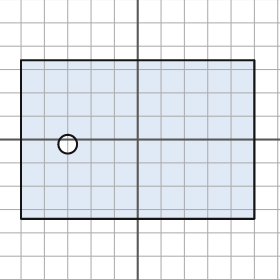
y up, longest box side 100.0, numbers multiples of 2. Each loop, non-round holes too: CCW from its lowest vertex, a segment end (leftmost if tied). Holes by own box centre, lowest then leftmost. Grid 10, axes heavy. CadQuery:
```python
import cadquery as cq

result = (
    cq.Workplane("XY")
    .moveTo(-50.0, -34.0)
    .lineTo(50.0, -34.0)
    .lineTo(50.0, 34.0)
    .lineTo(-50.0, 34.0)
    .close()
    .moveTo(-30.0, -2.0)
    .circle(4.0)
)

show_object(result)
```